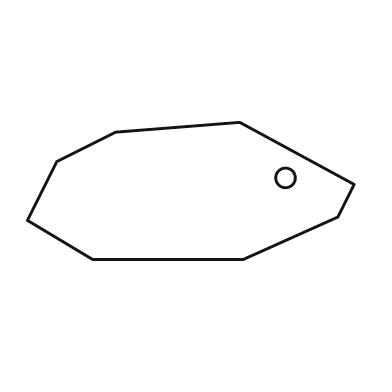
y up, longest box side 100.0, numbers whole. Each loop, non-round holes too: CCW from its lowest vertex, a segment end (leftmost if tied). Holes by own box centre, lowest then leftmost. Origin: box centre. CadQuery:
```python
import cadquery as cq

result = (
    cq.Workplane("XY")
    .moveTo(-30.0, -21.0)
    .lineTo(16.0, -21.0)
    .lineTo(45.0, -8.0)
    .lineTo(50.0, 2.0)
    .lineTo(15.0, 21.0)
    .lineTo(-23.0, 18.0)
    .lineTo(-41.0, 9.0)
    .lineTo(-50.0, -9.0)
    .close()
    .moveTo(29.0, 4.0)
    .circle(3.0)
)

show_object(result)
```